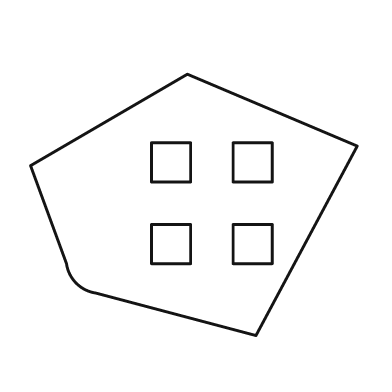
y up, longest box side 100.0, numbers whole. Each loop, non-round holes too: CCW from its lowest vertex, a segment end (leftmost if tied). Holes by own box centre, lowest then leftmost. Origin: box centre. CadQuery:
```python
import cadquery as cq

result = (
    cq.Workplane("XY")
    .moveTo(19.0, -40.0)
    .lineTo(50.0, 18.0)
    .lineTo(-2.0, 40.0)
    .lineTo(-50.0, 12.0)
    .lineTo(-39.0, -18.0)
    .threePointArc((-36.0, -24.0), (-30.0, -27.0))
    .close()
    .moveTo(-13.0, -18.0)
    .lineTo(-1.0, -18.0)
    .lineTo(-1.0, -6.0)
    .lineTo(-13.0, -6.0)
    .close()
    .moveTo(12.0, -18.0)
    .lineTo(24.0, -18.0)
    .lineTo(24.0, -6.0)
    .lineTo(12.0, -6.0)
    .close()
    .moveTo(-13.0, 7.0)
    .lineTo(-1.0, 7.0)
    .lineTo(-1.0, 19.0)
    .lineTo(-13.0, 19.0)
    .close()
    .moveTo(12.0, 7.0)
    .lineTo(24.0, 7.0)
    .lineTo(24.0, 19.0)
    .lineTo(12.0, 19.0)
    .close()
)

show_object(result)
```